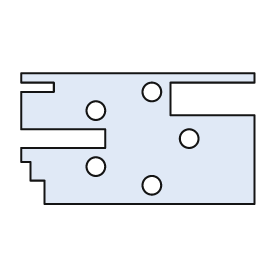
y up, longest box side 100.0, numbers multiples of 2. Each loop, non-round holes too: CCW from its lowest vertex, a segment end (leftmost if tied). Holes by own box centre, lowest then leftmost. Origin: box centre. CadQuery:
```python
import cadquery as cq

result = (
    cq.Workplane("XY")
    .moveTo(-40.0, -28.0)
    .lineTo(50.0, -28.0)
    .lineTo(50.0, 10.0)
    .lineTo(14.0, 10.0)
    .lineTo(14.0, 24.0)
    .lineTo(50.0, 24.0)
    .lineTo(50.0, 28.0)
    .lineTo(-50.0, 28.0)
    .lineTo(-50.0, 24.0)
    .lineTo(-36.0, 24.0)
    .lineTo(-36.0, 20.0)
    .lineTo(-50.0, 20.0)
    .lineTo(-50.0, 4.0)
    .lineTo(-14.0, 4.0)
    .lineTo(-14.0, -4.0)
    .lineTo(-50.0, -4.0)
    .lineTo(-50.0, -10.0)
    .lineTo(-46.0, -10.0)
    .lineTo(-46.0, -18.0)
    .lineTo(-40.0, -18.0)
    .close()
    .moveTo(6.0, -20.0)
    .circle(4.0)
    .moveTo(-18.0, -12.0)
    .circle(4.0)
    .moveTo(22.0, 0.0)
    .circle(4.0)
    .moveTo(-18.0, 12.0)
    .circle(4.0)
    .moveTo(6.0, 20.0)
    .circle(4.0)
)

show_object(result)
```